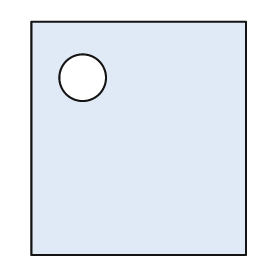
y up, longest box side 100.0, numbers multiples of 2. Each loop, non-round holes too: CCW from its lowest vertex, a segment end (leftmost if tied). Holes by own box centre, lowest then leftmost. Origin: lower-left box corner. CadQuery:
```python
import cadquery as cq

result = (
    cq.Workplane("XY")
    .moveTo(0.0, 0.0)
    .lineTo(92.0, 0.0)
    .lineTo(92.0, 100.0)
    .lineTo(0.0, 100.0)
    .close()
    .moveTo(22.0, 76.0)
    .circle(10.0)
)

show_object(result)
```